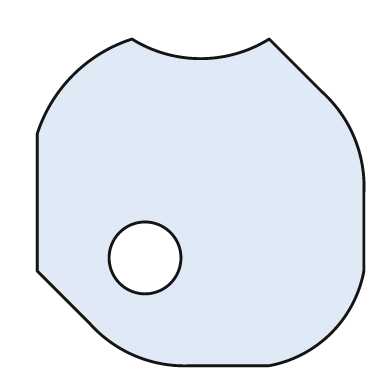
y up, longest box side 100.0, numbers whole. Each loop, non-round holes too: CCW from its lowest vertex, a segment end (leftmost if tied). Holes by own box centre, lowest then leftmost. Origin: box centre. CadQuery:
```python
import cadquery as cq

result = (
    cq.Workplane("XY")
    .moveTo(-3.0, -50.0)
    .lineTo(21.0, -50.0)
    .threePointArc((40.0, -40.0), (50.0, -21.0))
    .lineTo(50.0, 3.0)
    .threePointArc((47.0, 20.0), (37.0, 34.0))
    .lineTo(21.0, 50.0)
    .threePointArc((0.0, 44.0), (-21.0, 50.0))
    .threePointArc((-39.0, 39.0), (-50.0, 21.0))
    .lineTo(-50.0, -21.0)
    .lineTo(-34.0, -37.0)
    .threePointArc((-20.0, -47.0), (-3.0, -50.0))
    .close()
    .moveTo(-17.0, -17.0)
    .circle(11.0)
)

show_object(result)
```